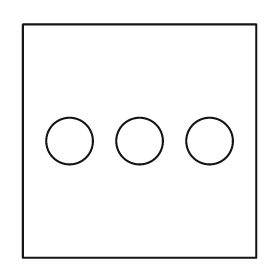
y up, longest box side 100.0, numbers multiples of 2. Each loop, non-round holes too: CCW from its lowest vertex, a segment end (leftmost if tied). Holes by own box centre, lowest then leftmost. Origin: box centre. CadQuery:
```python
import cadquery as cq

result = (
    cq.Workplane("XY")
    .moveTo(-50.0, -50.0)
    .lineTo(50.0, -50.0)
    .lineTo(50.0, 50.0)
    .lineTo(-50.0, 50.0)
    .close()
    .moveTo(-30.0, 0.0)
    .circle(10.0)
    .moveTo(0.0, 0.0)
    .circle(10.0)
    .moveTo(30.0, 0.0)
    .circle(10.0)
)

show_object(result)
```